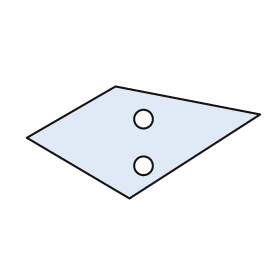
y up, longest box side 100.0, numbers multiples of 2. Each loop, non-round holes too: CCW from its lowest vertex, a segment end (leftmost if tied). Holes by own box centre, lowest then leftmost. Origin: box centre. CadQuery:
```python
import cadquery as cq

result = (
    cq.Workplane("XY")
    .moveTo(-6.0, -24.0)
    .lineTo(50.0, 12.0)
    .lineTo(-12.0, 24.0)
    .lineTo(-50.0, 2.0)
    .close()
    .moveTo(0.0, -10.0)
    .circle(4.0)
    .moveTo(0.0, 10.0)
    .circle(4.0)
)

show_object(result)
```